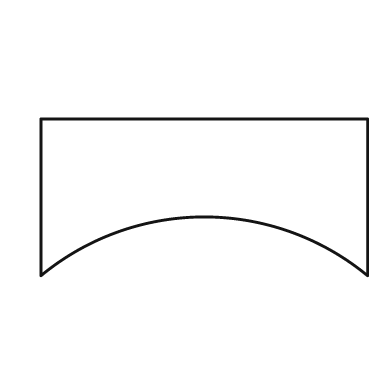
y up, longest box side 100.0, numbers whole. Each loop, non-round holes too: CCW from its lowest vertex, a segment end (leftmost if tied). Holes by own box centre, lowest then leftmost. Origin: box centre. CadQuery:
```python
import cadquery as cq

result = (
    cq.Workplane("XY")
    .moveTo(-50.0, -24.0)
    .threePointArc((0.0, -6.0), (50.0, -24.0))
    .lineTo(50.0, 24.0)
    .lineTo(-50.0, 24.0)
    .close()
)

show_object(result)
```